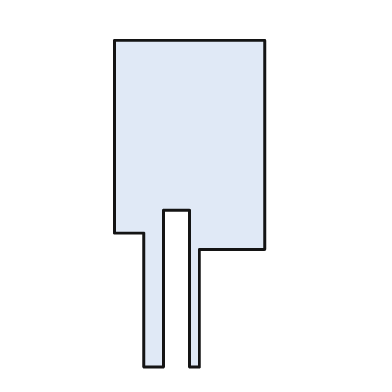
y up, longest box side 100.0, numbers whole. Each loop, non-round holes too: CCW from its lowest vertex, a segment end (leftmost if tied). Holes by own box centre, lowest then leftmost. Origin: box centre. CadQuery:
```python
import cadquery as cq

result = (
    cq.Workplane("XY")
    .moveTo(-14.0, -50.0)
    .lineTo(-8.0, -50.0)
    .lineTo(-8.0, -2.0)
    .lineTo(0.0, -2.0)
    .lineTo(0.0, -50.0)
    .lineTo(3.0, -50.0)
    .lineTo(3.0, -14.0)
    .lineTo(23.0, -14.0)
    .lineTo(23.0, 50.0)
    .lineTo(-23.0, 50.0)
    .lineTo(-23.0, -9.0)
    .lineTo(-14.0, -9.0)
    .close()
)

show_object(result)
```